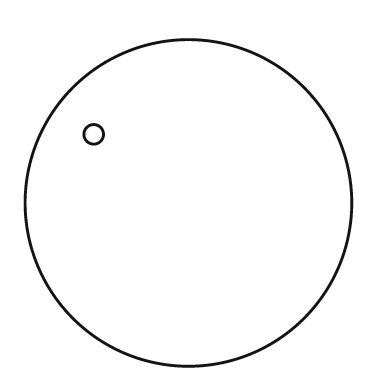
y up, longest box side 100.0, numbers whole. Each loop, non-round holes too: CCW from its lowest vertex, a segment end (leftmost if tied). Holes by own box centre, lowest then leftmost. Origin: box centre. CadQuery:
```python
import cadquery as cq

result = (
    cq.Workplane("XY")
    .moveTo(0.0, 0.0)
    .circle(50.0)
    .moveTo(-29.0, 21.0)
    .circle(3.0)
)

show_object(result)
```